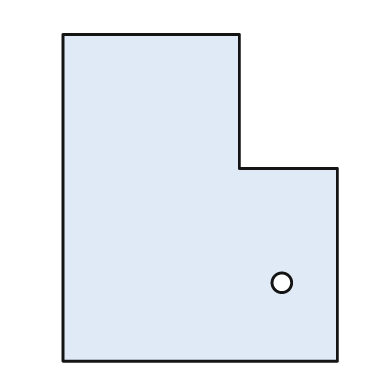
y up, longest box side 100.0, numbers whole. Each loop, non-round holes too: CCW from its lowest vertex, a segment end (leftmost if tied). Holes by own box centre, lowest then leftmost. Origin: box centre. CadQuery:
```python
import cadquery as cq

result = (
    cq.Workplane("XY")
    .moveTo(-42.0, -50.0)
    .lineTo(42.0, -50.0)
    .lineTo(42.0, 9.0)
    .lineTo(12.0, 9.0)
    .lineTo(12.0, 50.0)
    .lineTo(-42.0, 50.0)
    .close()
    .moveTo(25.0, -26.0)
    .circle(3.0)
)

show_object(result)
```